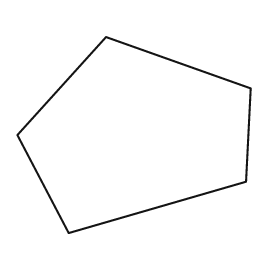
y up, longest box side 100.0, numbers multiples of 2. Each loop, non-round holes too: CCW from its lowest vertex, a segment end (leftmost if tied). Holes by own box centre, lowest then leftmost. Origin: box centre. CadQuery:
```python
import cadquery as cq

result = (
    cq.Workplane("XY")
    .moveTo(-28.0, -42.0)
    .lineTo(48.0, -20.0)
    .lineTo(50.0, 20.0)
    .lineTo(-12.0, 42.0)
    .lineTo(-50.0, 0.0)
    .close()
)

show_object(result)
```